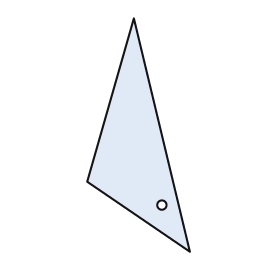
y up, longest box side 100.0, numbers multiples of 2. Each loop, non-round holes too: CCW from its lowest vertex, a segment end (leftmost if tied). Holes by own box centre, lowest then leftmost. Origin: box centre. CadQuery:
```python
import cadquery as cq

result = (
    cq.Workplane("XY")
    .moveTo(22.0, -50.0)
    .lineTo(-2.0, 50.0)
    .lineTo(-22.0, -20.0)
    .close()
    .moveTo(10.0, -30.0)
    .circle(2.0)
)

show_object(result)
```